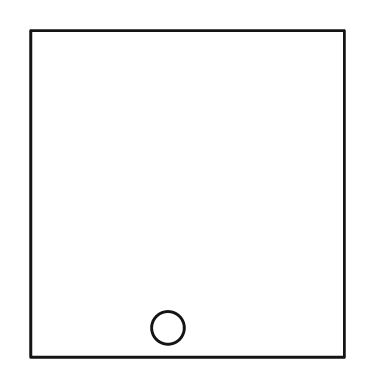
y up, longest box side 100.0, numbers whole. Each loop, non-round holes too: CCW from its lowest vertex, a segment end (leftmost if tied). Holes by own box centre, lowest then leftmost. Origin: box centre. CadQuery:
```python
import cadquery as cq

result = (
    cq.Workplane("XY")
    .moveTo(-48.0, -50.0)
    .lineTo(48.0, -50.0)
    .lineTo(48.0, 50.0)
    .lineTo(-48.0, 50.0)
    .close()
    .moveTo(-6.0, -41.0)
    .circle(5.0)
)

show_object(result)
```